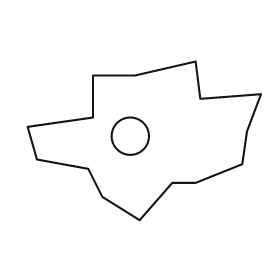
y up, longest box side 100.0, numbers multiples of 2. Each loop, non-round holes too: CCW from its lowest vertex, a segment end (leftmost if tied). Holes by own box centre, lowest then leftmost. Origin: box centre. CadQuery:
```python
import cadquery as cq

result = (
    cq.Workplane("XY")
    .moveTo(-2.0, -34.0)
    .lineTo(12.0, -18.0)
    .lineTo(22.0, -18.0)
    .lineTo(42.0, -10.0)
    .lineTo(44.0, 4.0)
    .lineTo(50.0, 20.0)
    .lineTo(24.0, 18.0)
    .lineTo(22.0, 34.0)
    .lineTo(-4.0, 28.0)
    .lineTo(-22.0, 28.0)
    .lineTo(-22.0, 10.0)
    .lineTo(-50.0, 6.0)
    .lineTo(-46.0, -8.0)
    .lineTo(-24.0, -12.0)
    .lineTo(-18.0, -24.0)
    .close()
    .moveTo(-6.0, 2.0)
    .circle(8.0)
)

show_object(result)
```